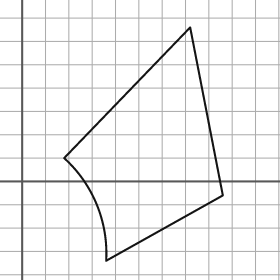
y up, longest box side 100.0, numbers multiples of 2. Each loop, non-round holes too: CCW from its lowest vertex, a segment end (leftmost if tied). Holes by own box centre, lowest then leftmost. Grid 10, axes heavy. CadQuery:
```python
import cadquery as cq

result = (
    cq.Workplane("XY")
    .moveTo(36.0, -34.0)
    .lineTo(86.0, -6.0)
    .lineTo(72.0, 66.0)
    .lineTo(18.0, 10.0)
    .threePointArc((32.0, -10.0), (36.0, -34.0))
    .close()
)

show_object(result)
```